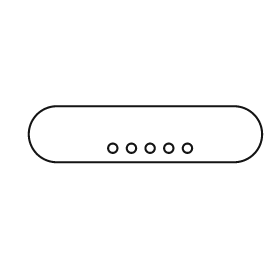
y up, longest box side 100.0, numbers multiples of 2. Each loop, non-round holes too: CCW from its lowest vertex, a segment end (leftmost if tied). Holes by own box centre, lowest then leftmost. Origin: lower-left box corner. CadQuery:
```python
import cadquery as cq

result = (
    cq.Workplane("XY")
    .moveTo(12.0, 0.0)
    .lineTo(88.0, 0.0)
    .threePointArc((100.0, 12.0), (88.0, 24.0))
    .lineTo(12.0, 24.0)
    .threePointArc((0.0, 12.0), (12.0, 0.0))
    .close()
    .moveTo(36.0, 6.0)
    .circle(2.0)
    .moveTo(44.0, 6.0)
    .circle(2.0)
    .moveTo(52.0, 6.0)
    .circle(2.0)
    .moveTo(60.0, 6.0)
    .circle(2.0)
    .moveTo(68.0, 6.0)
    .circle(2.0)
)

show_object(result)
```